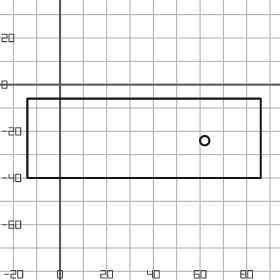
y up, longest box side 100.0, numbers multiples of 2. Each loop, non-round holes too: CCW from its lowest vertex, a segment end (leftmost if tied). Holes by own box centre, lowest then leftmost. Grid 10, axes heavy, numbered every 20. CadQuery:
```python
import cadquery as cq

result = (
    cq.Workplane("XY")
    .moveTo(-14.0, -40.0)
    .lineTo(86.0, -40.0)
    .lineTo(86.0, -6.0)
    .lineTo(-14.0, -6.0)
    .close()
    .moveTo(62.0, -24.0)
    .circle(2.0)
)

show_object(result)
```